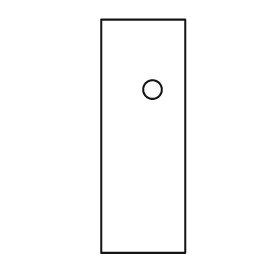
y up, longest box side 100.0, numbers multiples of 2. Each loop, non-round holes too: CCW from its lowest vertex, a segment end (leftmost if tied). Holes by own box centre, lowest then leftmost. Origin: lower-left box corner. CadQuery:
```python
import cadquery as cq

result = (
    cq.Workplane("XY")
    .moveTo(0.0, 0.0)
    .lineTo(36.0, 0.0)
    .lineTo(36.0, 100.0)
    .lineTo(0.0, 100.0)
    .close()
    .moveTo(22.0, 70.0)
    .circle(4.0)
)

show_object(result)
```